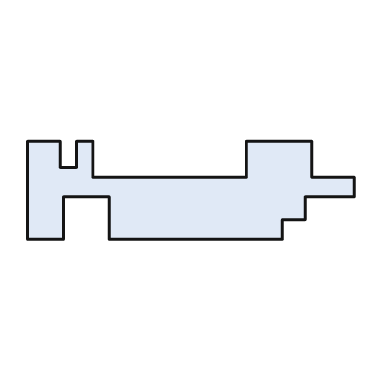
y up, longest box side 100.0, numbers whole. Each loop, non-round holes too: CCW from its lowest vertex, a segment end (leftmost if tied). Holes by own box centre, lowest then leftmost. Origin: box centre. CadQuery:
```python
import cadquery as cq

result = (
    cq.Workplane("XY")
    .moveTo(-50.0, -15.0)
    .lineTo(-39.0, -15.0)
    .lineTo(-39.0, -2.0)
    .lineTo(-25.0, -2.0)
    .lineTo(-25.0, -15.0)
    .lineTo(28.0, -15.0)
    .lineTo(28.0, -9.0)
    .lineTo(35.0, -9.0)
    .lineTo(35.0, -2.0)
    .lineTo(50.0, -2.0)
    .lineTo(50.0, 4.0)
    .lineTo(37.0, 4.0)
    .lineTo(37.0, 15.0)
    .lineTo(17.0, 15.0)
    .lineTo(17.0, 4.0)
    .lineTo(-30.0, 4.0)
    .lineTo(-30.0, 15.0)
    .lineTo(-35.0, 15.0)
    .lineTo(-35.0, 7.0)
    .lineTo(-40.0, 7.0)
    .lineTo(-40.0, 15.0)
    .lineTo(-50.0, 15.0)
    .close()
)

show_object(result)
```